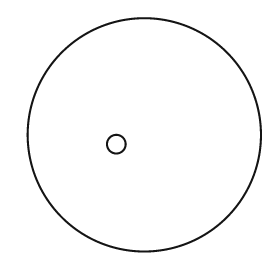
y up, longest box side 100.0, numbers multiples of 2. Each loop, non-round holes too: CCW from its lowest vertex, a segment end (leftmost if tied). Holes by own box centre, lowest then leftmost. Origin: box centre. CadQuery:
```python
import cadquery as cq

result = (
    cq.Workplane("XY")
    .moveTo(0.0, 0.0)
    .circle(50.0)
    .moveTo(-12.0, -4.0)
    .circle(4.0)
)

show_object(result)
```